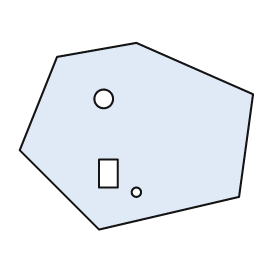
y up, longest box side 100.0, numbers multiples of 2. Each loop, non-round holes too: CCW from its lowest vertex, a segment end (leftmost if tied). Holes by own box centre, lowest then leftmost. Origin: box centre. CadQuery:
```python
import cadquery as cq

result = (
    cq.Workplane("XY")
    .moveTo(-16.0, -40.0)
    .lineTo(44.0, -26.0)
    .lineTo(50.0, 18.0)
    .lineTo(0.0, 40.0)
    .lineTo(-34.0, 34.0)
    .lineTo(-50.0, -6.0)
    .close()
    .moveTo(0.0, -24.0)
    .circle(2.0)
    .moveTo(-16.0, -22.0)
    .lineTo(-8.0, -22.0)
    .lineTo(-8.0, -10.0)
    .lineTo(-16.0, -10.0)
    .close()
    .moveTo(-14.0, 16.0)
    .circle(4.0)
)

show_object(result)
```